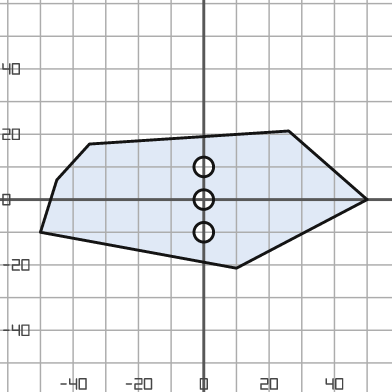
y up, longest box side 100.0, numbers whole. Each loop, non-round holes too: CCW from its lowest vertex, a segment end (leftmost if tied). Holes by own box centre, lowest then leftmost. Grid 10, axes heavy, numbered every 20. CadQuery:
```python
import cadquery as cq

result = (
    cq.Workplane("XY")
    .moveTo(10.0, -21.0)
    .lineTo(50.0, 0.0)
    .lineTo(26.0, 21.0)
    .lineTo(-35.0, 17.0)
    .lineTo(-45.0, 6.0)
    .lineTo(-50.0, -10.0)
    .close()
    .moveTo(0.0, -10.0)
    .circle(3.0)
    .moveTo(0.0, 0.0)
    .circle(3.0)
    .moveTo(0.0, 10.0)
    .circle(3.0)
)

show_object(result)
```